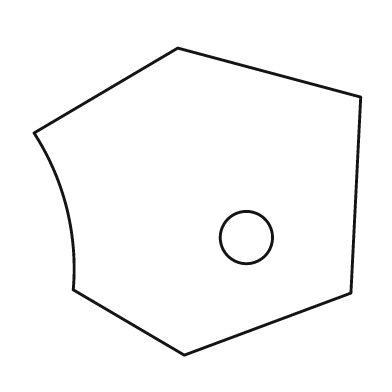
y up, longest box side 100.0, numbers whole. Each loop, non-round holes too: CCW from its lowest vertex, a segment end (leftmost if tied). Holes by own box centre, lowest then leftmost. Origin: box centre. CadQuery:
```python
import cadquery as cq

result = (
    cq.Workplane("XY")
    .moveTo(-4.0, -47.0)
    .lineTo(47.0, -28.0)
    .lineTo(50.0, 32.0)
    .lineTo(-6.0, 47.0)
    .lineTo(-50.0, 21.0)
    .threePointArc((-40.0, -2.0), (-38.0, -27.0))
    .close()
    .moveTo(15.0, -11.0)
    .circle(8.0)
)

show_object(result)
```